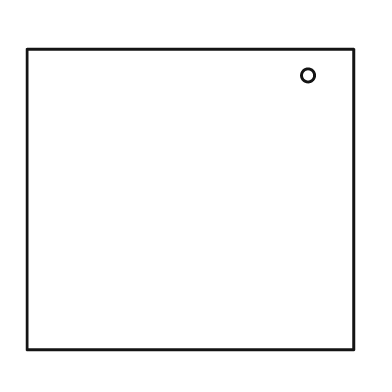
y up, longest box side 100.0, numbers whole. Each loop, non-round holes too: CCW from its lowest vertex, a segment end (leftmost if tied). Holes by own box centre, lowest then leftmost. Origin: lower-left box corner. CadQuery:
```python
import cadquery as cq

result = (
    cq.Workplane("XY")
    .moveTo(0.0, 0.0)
    .lineTo(100.0, 0.0)
    .lineTo(100.0, 92.0)
    .lineTo(0.0, 92.0)
    .close()
    .moveTo(86.0, 84.0)
    .circle(2.0)
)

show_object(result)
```